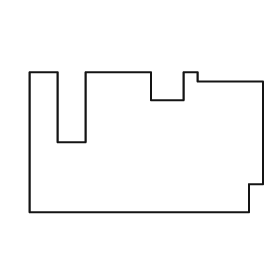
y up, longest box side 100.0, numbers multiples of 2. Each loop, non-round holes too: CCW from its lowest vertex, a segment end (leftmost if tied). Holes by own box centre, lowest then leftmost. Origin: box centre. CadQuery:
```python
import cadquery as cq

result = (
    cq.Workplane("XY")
    .moveTo(-50.0, -30.0)
    .lineTo(44.0, -30.0)
    .lineTo(44.0, -18.0)
    .lineTo(50.0, -18.0)
    .lineTo(50.0, 26.0)
    .lineTo(22.0, 26.0)
    .lineTo(22.0, 30.0)
    .lineTo(16.0, 30.0)
    .lineTo(16.0, 18.0)
    .lineTo(2.0, 18.0)
    .lineTo(2.0, 30.0)
    .lineTo(-26.0, 30.0)
    .lineTo(-26.0, 0.0)
    .lineTo(-38.0, 0.0)
    .lineTo(-38.0, 30.0)
    .lineTo(-50.0, 30.0)
    .close()
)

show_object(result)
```